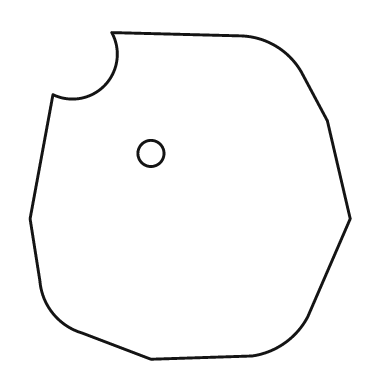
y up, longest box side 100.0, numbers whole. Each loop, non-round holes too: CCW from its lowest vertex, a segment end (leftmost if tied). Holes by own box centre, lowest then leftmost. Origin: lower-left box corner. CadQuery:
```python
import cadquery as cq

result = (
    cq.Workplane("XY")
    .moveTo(37.0, 0.0)
    .lineTo(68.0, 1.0)
    .threePointArc((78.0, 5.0), (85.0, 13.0))
    .lineTo(98.0, 43.0)
    .lineTo(91.0, 73.0)
    .lineTo(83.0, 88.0)
    .threePointArc((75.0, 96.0), (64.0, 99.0))
    .lineTo(25.0, 100.0)
    .threePointArc((23.0, 84.0), (7.0, 81.0))
    .lineTo(0.0, 43.0)
    .lineTo(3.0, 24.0)
    .threePointArc((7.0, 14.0), (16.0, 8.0))
    .close()
    .moveTo(37.0, 63.0)
    .circle(4.0)
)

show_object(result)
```